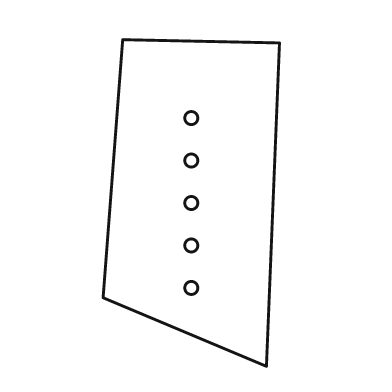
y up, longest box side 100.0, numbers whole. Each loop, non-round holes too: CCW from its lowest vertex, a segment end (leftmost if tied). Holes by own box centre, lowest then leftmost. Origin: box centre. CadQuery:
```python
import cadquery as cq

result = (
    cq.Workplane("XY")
    .moveTo(23.0, -50.0)
    .lineTo(27.0, 49.0)
    .lineTo(-21.0, 50.0)
    .lineTo(-27.0, -29.0)
    .close()
    .moveTo(0.0, -26.0)
    .circle(2.0)
    .moveTo(0.0, -13.0)
    .circle(2.0)
    .moveTo(0.0, 0.0)
    .circle(2.0)
    .moveTo(0.0, 13.0)
    .circle(2.0)
    .moveTo(0.0, 26.0)
    .circle(2.0)
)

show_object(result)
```